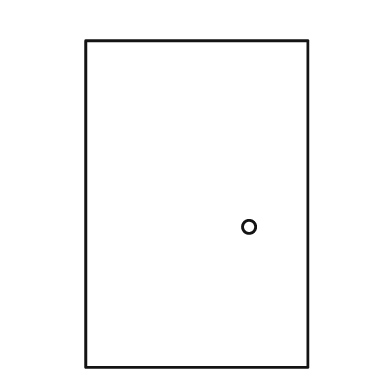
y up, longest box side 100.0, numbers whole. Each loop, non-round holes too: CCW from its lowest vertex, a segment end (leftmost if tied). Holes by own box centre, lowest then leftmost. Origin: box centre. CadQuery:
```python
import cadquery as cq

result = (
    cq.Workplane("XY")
    .moveTo(-34.0, -50.0)
    .lineTo(34.0, -50.0)
    .lineTo(34.0, 50.0)
    .lineTo(-34.0, 50.0)
    .close()
    .moveTo(16.0, -7.0)
    .circle(2.0)
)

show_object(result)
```